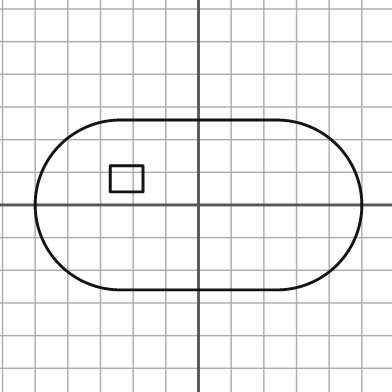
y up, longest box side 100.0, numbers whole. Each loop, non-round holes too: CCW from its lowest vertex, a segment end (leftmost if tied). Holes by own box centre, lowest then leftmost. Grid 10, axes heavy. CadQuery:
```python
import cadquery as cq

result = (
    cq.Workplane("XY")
    .moveTo(-24.0, -26.0)
    .lineTo(24.0, -26.0)
    .threePointArc((50.0, 0.0), (24.0, 26.0))
    .lineTo(-24.0, 26.0)
    .threePointArc((-50.0, 0.0), (-24.0, -26.0))
    .close()
    .moveTo(-27.0, 4.0)
    .lineTo(-17.0, 4.0)
    .lineTo(-17.0, 12.0)
    .lineTo(-27.0, 12.0)
    .close()
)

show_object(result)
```